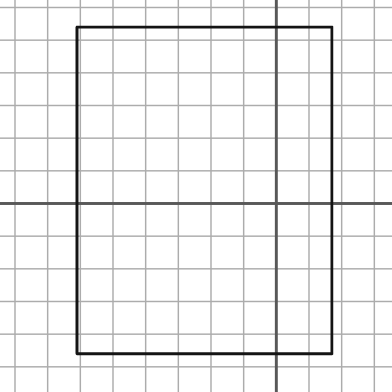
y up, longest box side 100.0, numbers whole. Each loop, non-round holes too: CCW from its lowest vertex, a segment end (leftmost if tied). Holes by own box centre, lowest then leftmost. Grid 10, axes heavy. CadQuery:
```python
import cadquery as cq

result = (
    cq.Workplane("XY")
    .moveTo(-61.0, -46.0)
    .lineTo(17.0, -46.0)
    .lineTo(17.0, 54.0)
    .lineTo(-61.0, 54.0)
    .close()
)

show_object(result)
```